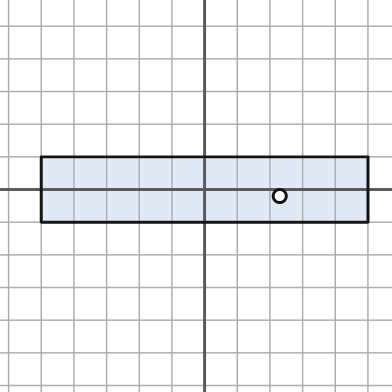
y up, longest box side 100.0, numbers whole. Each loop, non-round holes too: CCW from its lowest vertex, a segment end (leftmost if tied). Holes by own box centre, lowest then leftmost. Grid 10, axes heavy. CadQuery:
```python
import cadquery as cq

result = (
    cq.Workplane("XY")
    .moveTo(-50.0, -10.0)
    .lineTo(50.0, -10.0)
    .lineTo(50.0, 10.0)
    .lineTo(-50.0, 10.0)
    .close()
    .moveTo(23.0, -2.0)
    .circle(2.0)
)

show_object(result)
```